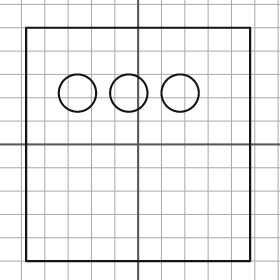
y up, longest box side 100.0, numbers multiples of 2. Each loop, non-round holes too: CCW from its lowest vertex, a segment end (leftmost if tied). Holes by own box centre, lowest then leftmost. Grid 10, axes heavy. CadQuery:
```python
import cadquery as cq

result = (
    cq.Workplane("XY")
    .moveTo(-48.0, -50.0)
    .lineTo(48.0, -50.0)
    .lineTo(48.0, 50.0)
    .lineTo(-48.0, 50.0)
    .close()
    .moveTo(-26.0, 22.0)
    .circle(8.0)
    .moveTo(-4.0, 22.0)
    .circle(8.0)
    .moveTo(18.0, 22.0)
    .circle(8.0)
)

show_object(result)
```